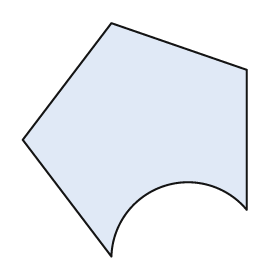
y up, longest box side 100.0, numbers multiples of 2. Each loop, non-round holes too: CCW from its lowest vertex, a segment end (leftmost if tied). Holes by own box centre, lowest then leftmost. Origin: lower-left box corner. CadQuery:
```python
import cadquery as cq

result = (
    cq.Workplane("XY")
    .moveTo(38.0, 0.0)
    .threePointArc((60.0, 30.0), (96.0, 20.0))
    .lineTo(96.0, 80.0)
    .lineTo(38.0, 100.0)
    .lineTo(0.0, 50.0)
    .close()
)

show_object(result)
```